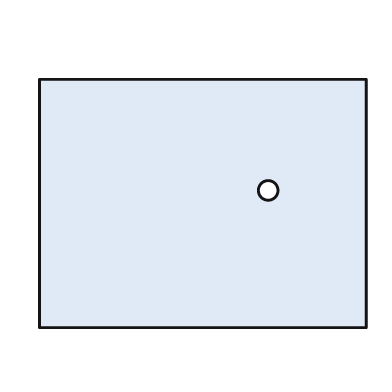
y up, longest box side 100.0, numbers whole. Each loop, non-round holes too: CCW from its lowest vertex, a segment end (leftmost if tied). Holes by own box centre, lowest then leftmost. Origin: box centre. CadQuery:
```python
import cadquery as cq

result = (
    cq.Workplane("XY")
    .moveTo(-50.0, -38.0)
    .lineTo(50.0, -38.0)
    .lineTo(50.0, 38.0)
    .lineTo(-50.0, 38.0)
    .close()
    .moveTo(20.0, 4.0)
    .circle(3.0)
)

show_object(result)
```